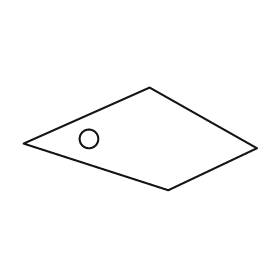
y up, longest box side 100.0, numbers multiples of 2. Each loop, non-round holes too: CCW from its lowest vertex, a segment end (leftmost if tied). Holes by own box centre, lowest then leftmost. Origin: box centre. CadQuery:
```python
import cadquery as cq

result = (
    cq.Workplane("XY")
    .moveTo(12.0, -22.0)
    .lineTo(50.0, -4.0)
    .lineTo(4.0, 22.0)
    .lineTo(-50.0, -2.0)
    .close()
    .moveTo(-22.0, 0.0)
    .circle(4.0)
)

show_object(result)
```